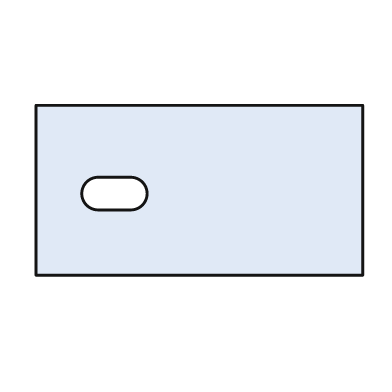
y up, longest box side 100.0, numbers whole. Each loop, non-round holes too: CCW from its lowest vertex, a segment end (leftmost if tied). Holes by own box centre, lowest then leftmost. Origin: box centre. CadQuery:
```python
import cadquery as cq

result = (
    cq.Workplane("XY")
    .moveTo(-50.0, -26.0)
    .lineTo(50.0, -26.0)
    .lineTo(50.0, 26.0)
    .lineTo(-50.0, 26.0)
    .close()
    .moveTo(-31.0, -6.0)
    .lineTo(-21.0, -6.0)
    .threePointArc((-16.0, -1.0), (-21.0, 4.0))
    .lineTo(-31.0, 4.0)
    .threePointArc((-36.0, -1.0), (-31.0, -6.0))
    .close()
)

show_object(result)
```